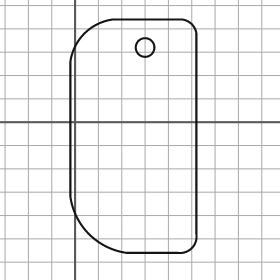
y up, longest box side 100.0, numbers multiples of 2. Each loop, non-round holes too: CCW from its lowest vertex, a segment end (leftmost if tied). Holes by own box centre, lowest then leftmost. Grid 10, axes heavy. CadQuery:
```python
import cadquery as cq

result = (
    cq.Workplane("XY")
    .moveTo(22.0, -56.0)
    .lineTo(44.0, -56.0)
    .threePointArc((50.0, -54.0), (52.0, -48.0))
    .lineTo(52.0, 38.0)
    .threePointArc((50.0, 42.0), (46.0, 44.0))
    .lineTo(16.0, 44.0)
    .threePointArc((4.0, 38.0), (-2.0, 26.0))
    .lineTo(-2.0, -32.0)
    .threePointArc((6.0, -48.0), (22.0, -56.0))
    .close()
    .moveTo(30.0, 32.0)
    .circle(4.0)
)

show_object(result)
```